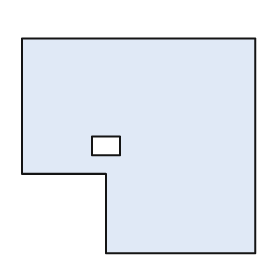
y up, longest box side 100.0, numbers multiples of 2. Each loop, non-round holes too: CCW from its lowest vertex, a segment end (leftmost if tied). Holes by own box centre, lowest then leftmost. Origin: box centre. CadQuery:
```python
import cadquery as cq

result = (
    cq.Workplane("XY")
    .moveTo(-14.0, -46.0)
    .lineTo(50.0, -46.0)
    .lineTo(50.0, 46.0)
    .lineTo(-50.0, 46.0)
    .lineTo(-50.0, -12.0)
    .lineTo(-14.0, -12.0)
    .close()
    .moveTo(-20.0, -4.0)
    .lineTo(-8.0, -4.0)
    .lineTo(-8.0, 4.0)
    .lineTo(-20.0, 4.0)
    .close()
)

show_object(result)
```